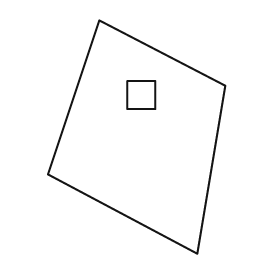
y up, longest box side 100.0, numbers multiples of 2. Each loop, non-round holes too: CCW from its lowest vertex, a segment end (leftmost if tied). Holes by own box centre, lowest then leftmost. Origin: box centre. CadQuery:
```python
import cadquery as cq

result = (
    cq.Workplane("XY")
    .moveTo(26.0, -50.0)
    .lineTo(38.0, 22.0)
    .lineTo(-16.0, 50.0)
    .lineTo(-38.0, -16.0)
    .close()
    .moveTo(-4.0, 12.0)
    .lineTo(8.0, 12.0)
    .lineTo(8.0, 24.0)
    .lineTo(-4.0, 24.0)
    .close()
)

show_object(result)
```